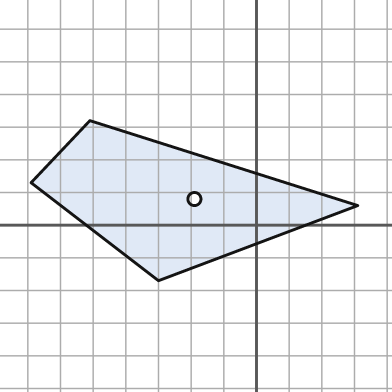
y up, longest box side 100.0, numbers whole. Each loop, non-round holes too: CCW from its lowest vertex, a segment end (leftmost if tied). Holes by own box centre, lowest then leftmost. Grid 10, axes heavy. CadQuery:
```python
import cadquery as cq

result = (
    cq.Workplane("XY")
    .moveTo(-30.0, -17.0)
    .lineTo(31.0, 6.0)
    .lineTo(-51.0, 32.0)
    .lineTo(-69.0, 13.0)
    .close()
    .moveTo(-19.0, 8.0)
    .circle(2.0)
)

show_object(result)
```